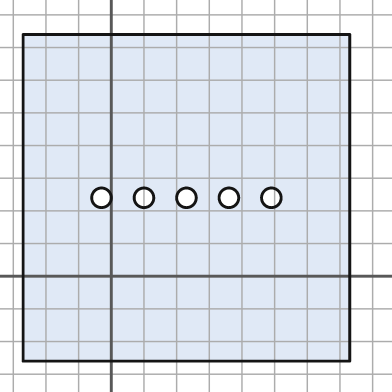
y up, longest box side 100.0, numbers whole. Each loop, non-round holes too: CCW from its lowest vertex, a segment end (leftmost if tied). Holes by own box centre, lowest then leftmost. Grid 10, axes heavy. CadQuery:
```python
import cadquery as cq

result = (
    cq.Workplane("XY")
    .moveTo(-27.0, -26.0)
    .lineTo(73.0, -26.0)
    .lineTo(73.0, 74.0)
    .lineTo(-27.0, 74.0)
    .close()
    .moveTo(-3.0, 24.0)
    .circle(3.0)
    .moveTo(10.0, 24.0)
    .circle(3.0)
    .moveTo(23.0, 24.0)
    .circle(3.0)
    .moveTo(36.0, 24.0)
    .circle(3.0)
    .moveTo(49.0, 24.0)
    .circle(3.0)
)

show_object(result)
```